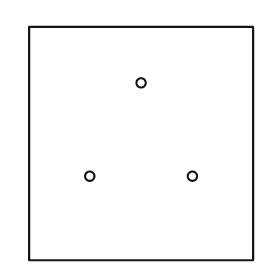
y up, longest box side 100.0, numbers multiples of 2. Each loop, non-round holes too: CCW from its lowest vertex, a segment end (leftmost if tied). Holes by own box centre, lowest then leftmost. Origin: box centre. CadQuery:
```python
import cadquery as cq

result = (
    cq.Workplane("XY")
    .moveTo(-48.0, -50.0)
    .lineTo(48.0, -50.0)
    .lineTo(48.0, 50.0)
    .lineTo(-48.0, 50.0)
    .close()
    .moveTo(-22.0, -14.0)
    .circle(2.0)
    .moveTo(22.0, -14.0)
    .circle(2.0)
    .moveTo(0.0, 26.0)
    .circle(2.0)
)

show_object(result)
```